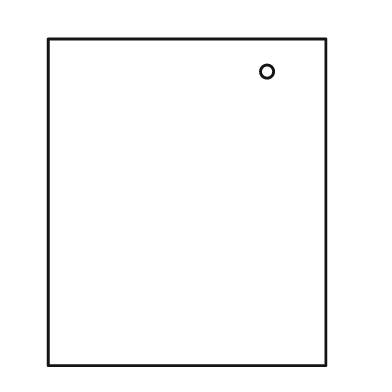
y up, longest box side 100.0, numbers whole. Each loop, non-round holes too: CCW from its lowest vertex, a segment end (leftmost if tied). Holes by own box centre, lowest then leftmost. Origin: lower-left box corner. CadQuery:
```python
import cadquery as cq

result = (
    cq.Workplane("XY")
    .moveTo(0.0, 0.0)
    .lineTo(85.0, 0.0)
    .lineTo(85.0, 100.0)
    .lineTo(0.0, 100.0)
    .close()
    .moveTo(67.0, 90.0)
    .circle(2.0)
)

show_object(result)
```